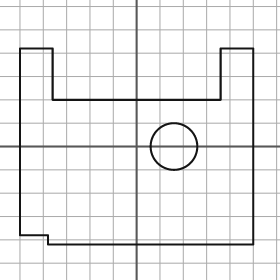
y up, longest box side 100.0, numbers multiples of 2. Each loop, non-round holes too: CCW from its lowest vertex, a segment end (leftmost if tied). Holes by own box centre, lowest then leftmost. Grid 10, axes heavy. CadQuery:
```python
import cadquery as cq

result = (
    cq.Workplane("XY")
    .moveTo(-38.0, -42.0)
    .lineTo(50.0, -42.0)
    .lineTo(50.0, 42.0)
    .lineTo(36.0, 42.0)
    .lineTo(36.0, 20.0)
    .lineTo(-36.0, 20.0)
    .lineTo(-36.0, 42.0)
    .lineTo(-50.0, 42.0)
    .lineTo(-50.0, -38.0)
    .lineTo(-38.0, -38.0)
    .close()
    .moveTo(16.0, 0.0)
    .circle(10.0)
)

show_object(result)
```